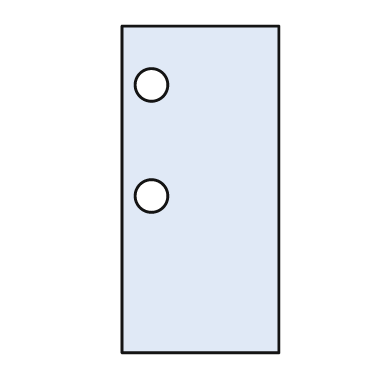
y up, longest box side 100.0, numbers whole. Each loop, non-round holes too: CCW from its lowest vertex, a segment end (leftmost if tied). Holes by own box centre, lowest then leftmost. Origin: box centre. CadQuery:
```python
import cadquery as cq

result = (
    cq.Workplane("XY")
    .moveTo(-24.0, -50.0)
    .lineTo(24.0, -50.0)
    .lineTo(24.0, 50.0)
    .lineTo(-24.0, 50.0)
    .close()
    .moveTo(-15.0, -2.0)
    .circle(5.0)
    .moveTo(-15.0, 32.0)
    .circle(5.0)
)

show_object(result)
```